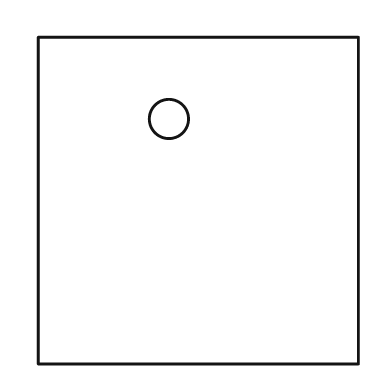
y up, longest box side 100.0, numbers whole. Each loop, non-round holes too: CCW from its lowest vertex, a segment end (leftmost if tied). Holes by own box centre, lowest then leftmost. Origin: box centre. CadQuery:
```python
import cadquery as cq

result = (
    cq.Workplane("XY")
    .moveTo(-49.0, -50.0)
    .lineTo(49.0, -50.0)
    .lineTo(49.0, 50.0)
    .lineTo(-49.0, 50.0)
    .close()
    .moveTo(-9.0, 25.0)
    .circle(6.0)
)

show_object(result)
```